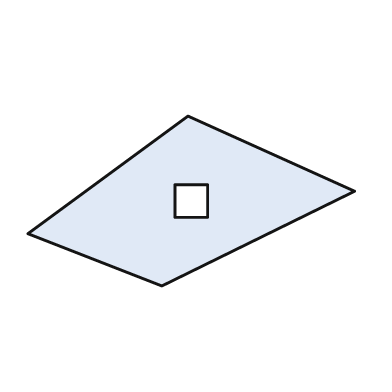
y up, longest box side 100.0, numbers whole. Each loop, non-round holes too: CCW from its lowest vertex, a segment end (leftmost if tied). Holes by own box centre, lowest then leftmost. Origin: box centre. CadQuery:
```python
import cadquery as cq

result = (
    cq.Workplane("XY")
    .moveTo(-9.0, -26.0)
    .lineTo(50.0, 3.0)
    .lineTo(-1.0, 26.0)
    .lineTo(-50.0, -10.0)
    .close()
    .moveTo(-5.0, -5.0)
    .lineTo(5.0, -5.0)
    .lineTo(5.0, 5.0)
    .lineTo(-5.0, 5.0)
    .close()
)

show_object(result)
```